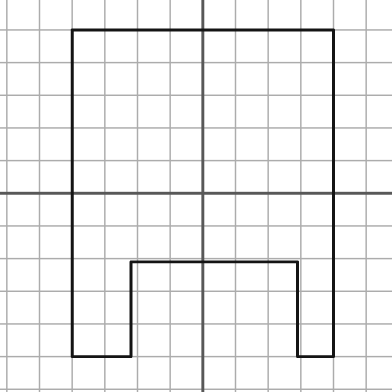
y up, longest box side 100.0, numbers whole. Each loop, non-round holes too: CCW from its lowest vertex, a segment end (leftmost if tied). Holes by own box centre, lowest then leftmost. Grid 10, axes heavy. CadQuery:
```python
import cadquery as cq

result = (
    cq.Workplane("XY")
    .moveTo(-40.0, -50.0)
    .lineTo(-22.0, -50.0)
    .lineTo(-22.0, -21.0)
    .lineTo(29.0, -21.0)
    .lineTo(29.0, -50.0)
    .lineTo(40.0, -50.0)
    .lineTo(40.0, 50.0)
    .lineTo(-40.0, 50.0)
    .close()
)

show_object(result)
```